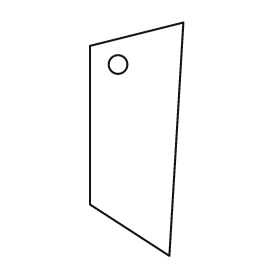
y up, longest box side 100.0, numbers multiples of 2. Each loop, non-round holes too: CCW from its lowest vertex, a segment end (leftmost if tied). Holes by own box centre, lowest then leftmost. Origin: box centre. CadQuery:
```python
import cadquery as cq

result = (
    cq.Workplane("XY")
    .moveTo(14.0, -50.0)
    .lineTo(20.0, 50.0)
    .lineTo(-20.0, 40.0)
    .lineTo(-20.0, -28.0)
    .close()
    .moveTo(-8.0, 32.0)
    .circle(4.0)
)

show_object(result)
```